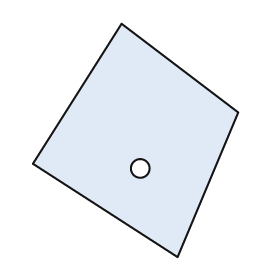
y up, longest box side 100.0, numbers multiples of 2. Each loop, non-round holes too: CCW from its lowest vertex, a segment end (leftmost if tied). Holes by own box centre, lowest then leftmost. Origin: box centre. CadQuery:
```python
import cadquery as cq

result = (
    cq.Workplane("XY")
    .moveTo(18.0, -50.0)
    .lineTo(44.0, 12.0)
    .lineTo(-6.0, 50.0)
    .lineTo(-44.0, -10.0)
    .close()
    .moveTo(2.0, -12.0)
    .circle(4.0)
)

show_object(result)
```